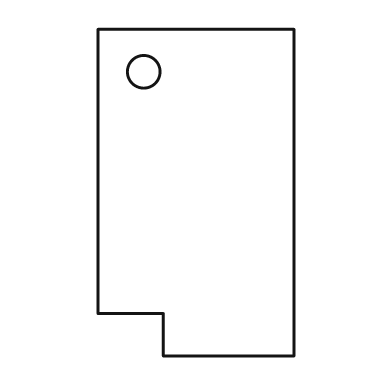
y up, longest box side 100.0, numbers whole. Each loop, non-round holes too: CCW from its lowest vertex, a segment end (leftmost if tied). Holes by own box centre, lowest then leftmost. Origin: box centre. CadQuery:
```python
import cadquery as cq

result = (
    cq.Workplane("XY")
    .moveTo(-10.0, -50.0)
    .lineTo(30.0, -50.0)
    .lineTo(30.0, 50.0)
    .lineTo(-30.0, 50.0)
    .lineTo(-30.0, -37.0)
    .lineTo(-10.0, -37.0)
    .close()
    .moveTo(-16.0, 37.0)
    .circle(5.0)
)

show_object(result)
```